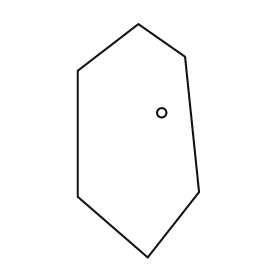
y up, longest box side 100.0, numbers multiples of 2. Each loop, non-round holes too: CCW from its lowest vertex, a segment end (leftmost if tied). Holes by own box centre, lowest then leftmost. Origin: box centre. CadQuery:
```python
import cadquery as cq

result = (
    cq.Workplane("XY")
    .moveTo(4.0, -50.0)
    .lineTo(26.0, -22.0)
    .lineTo(20.0, 36.0)
    .lineTo(0.0, 50.0)
    .lineTo(-26.0, 30.0)
    .lineTo(-26.0, -24.0)
    .close()
    .moveTo(10.0, 12.0)
    .circle(2.0)
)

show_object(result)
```